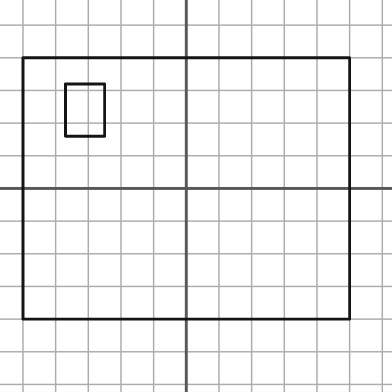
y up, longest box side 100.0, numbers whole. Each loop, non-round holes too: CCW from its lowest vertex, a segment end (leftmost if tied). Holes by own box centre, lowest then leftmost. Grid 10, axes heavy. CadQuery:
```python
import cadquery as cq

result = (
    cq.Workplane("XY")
    .moveTo(-50.0, -40.0)
    .lineTo(50.0, -40.0)
    .lineTo(50.0, 40.0)
    .lineTo(-50.0, 40.0)
    .close()
    .moveTo(-37.0, 16.0)
    .lineTo(-25.0, 16.0)
    .lineTo(-25.0, 32.0)
    .lineTo(-37.0, 32.0)
    .close()
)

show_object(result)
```